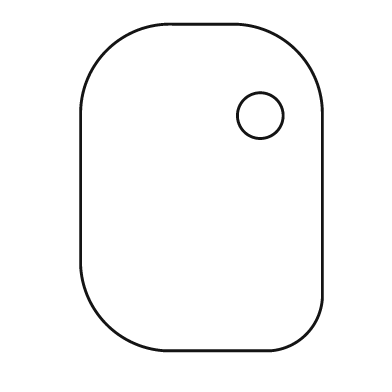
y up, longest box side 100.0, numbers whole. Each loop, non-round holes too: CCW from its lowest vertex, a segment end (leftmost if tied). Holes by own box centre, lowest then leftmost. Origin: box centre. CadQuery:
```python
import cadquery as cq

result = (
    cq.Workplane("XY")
    .moveTo(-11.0, -50.0)
    .lineTo(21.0, -50.0)
    .threePointArc((32.0, -45.0), (37.0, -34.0))
    .lineTo(37.0, 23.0)
    .threePointArc((29.0, 42.0), (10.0, 50.0))
    .lineTo(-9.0, 50.0)
    .threePointArc((-29.0, 42.0), (-37.0, 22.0))
    .lineTo(-37.0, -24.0)
    .threePointArc((-29.0, -42.0), (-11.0, -50.0))
    .close()
    .moveTo(18.0, 22.0)
    .circle(7.0)
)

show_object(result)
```